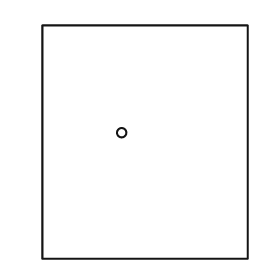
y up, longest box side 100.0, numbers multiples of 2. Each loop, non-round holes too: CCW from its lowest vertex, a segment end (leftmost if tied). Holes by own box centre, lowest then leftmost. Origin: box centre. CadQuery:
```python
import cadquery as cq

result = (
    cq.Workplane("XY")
    .moveTo(-44.0, -50.0)
    .lineTo(44.0, -50.0)
    .lineTo(44.0, 50.0)
    .lineTo(-44.0, 50.0)
    .close()
    .moveTo(-10.0, 4.0)
    .circle(2.0)
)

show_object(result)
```